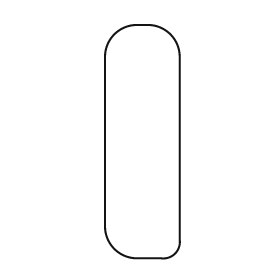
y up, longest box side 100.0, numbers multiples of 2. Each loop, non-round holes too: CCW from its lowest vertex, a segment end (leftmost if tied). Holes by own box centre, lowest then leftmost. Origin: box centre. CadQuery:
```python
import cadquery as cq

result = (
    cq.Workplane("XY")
    .moveTo(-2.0, -50.0)
    .lineTo(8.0, -50.0)
    .threePointArc((14.0, -48.0), (16.0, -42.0))
    .lineTo(16.0, 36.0)
    .threePointArc((12.0, 46.0), (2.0, 50.0))
    .lineTo(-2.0, 50.0)
    .threePointArc((-12.0, 46.0), (-16.0, 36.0))
    .lineTo(-16.0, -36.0)
    .threePointArc((-12.0, -46.0), (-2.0, -50.0))
    .close()
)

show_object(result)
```